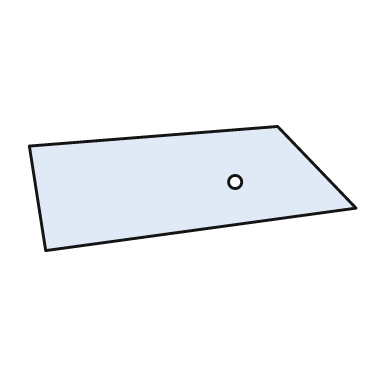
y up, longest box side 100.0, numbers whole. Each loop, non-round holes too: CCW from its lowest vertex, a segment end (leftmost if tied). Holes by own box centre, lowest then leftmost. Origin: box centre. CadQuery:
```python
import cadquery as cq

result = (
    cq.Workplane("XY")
    .moveTo(-45.0, -19.0)
    .lineTo(50.0, -6.0)
    .lineTo(26.0, 19.0)
    .lineTo(-50.0, 13.0)
    .close()
    .moveTo(13.0, 2.0)
    .circle(2.0)
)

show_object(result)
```